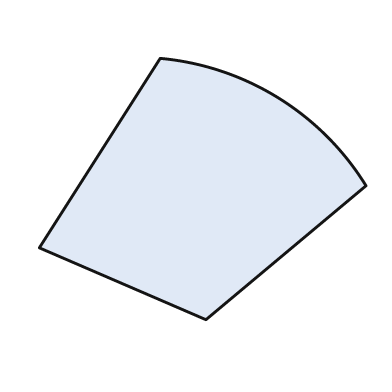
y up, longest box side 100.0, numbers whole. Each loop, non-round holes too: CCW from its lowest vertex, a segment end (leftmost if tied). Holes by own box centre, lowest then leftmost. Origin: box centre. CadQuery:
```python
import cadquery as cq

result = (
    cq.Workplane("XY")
    .moveTo(1.0, -40.0)
    .lineTo(50.0, 1.0)
    .threePointArc((23.0, 28.0), (-13.0, 40.0))
    .lineTo(-50.0, -18.0)
    .close()
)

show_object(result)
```